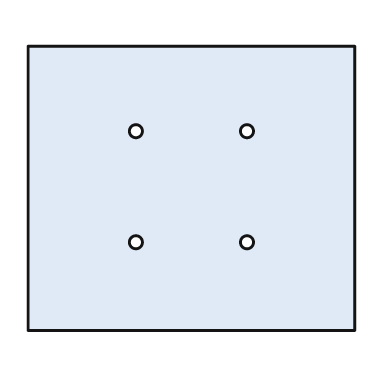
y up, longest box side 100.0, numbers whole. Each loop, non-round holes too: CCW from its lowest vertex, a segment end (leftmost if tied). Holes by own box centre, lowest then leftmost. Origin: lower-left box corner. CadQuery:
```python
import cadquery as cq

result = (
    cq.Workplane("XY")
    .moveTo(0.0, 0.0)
    .lineTo(100.0, 0.0)
    .lineTo(100.0, 87.0)
    .lineTo(0.0, 87.0)
    .close()
    .moveTo(33.0, 27.0)
    .circle(2.0)
    .moveTo(67.0, 27.0)
    .circle(2.0)
    .moveTo(33.0, 61.0)
    .circle(2.0)
    .moveTo(67.0, 61.0)
    .circle(2.0)
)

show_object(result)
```